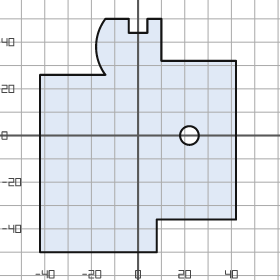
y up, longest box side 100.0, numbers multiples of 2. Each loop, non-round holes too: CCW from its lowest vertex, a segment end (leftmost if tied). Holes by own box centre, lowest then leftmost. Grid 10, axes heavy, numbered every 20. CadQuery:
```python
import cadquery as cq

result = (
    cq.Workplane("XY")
    .moveTo(-42.0, -50.0)
    .lineTo(8.0, -50.0)
    .lineTo(8.0, -36.0)
    .lineTo(42.0, -36.0)
    .lineTo(42.0, 32.0)
    .lineTo(10.0, 32.0)
    .lineTo(10.0, 50.0)
    .lineTo(4.0, 50.0)
    .lineTo(4.0, 44.0)
    .lineTo(-4.0, 44.0)
    .lineTo(-4.0, 50.0)
    .lineTo(-14.0, 50.0)
    .threePointArc((-18.0, 38.0), (-14.0, 26.0))
    .lineTo(-42.0, 26.0)
    .close()
    .moveTo(22.0, 0.0)
    .circle(4.0)
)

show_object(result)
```